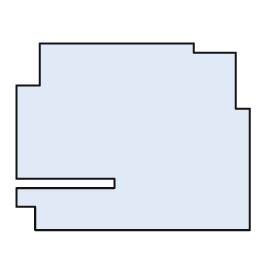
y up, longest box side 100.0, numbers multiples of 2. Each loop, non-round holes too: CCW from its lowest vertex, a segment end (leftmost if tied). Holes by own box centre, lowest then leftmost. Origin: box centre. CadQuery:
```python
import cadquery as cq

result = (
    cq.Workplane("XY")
    .moveTo(-42.0, -40.0)
    .lineTo(50.0, -40.0)
    .lineTo(50.0, 12.0)
    .lineTo(44.0, 12.0)
    .lineTo(44.0, 36.0)
    .lineTo(26.0, 36.0)
    .lineTo(26.0, 40.0)
    .lineTo(-40.0, 40.0)
    .lineTo(-40.0, 22.0)
    .lineTo(-50.0, 22.0)
    .lineTo(-50.0, -18.0)
    .lineTo(-8.0, -18.0)
    .lineTo(-8.0, -22.0)
    .lineTo(-50.0, -22.0)
    .lineTo(-50.0, -30.0)
    .lineTo(-42.0, -30.0)
    .close()
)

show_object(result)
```